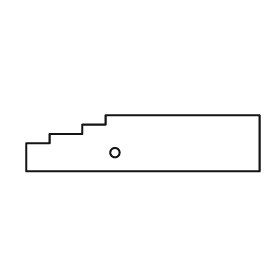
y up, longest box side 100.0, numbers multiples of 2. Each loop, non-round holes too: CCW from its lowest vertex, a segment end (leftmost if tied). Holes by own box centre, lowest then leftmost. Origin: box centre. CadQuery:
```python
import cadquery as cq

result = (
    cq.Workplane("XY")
    .moveTo(-50.0, -12.0)
    .lineTo(50.0, -12.0)
    .lineTo(50.0, 12.0)
    .lineTo(-16.0, 12.0)
    .lineTo(-16.0, 8.0)
    .lineTo(-26.0, 8.0)
    .lineTo(-26.0, 4.0)
    .lineTo(-40.0, 4.0)
    .lineTo(-40.0, 0.0)
    .lineTo(-50.0, 0.0)
    .close()
    .moveTo(-12.0, -4.0)
    .circle(2.0)
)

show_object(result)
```